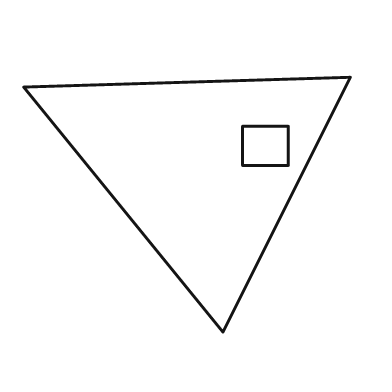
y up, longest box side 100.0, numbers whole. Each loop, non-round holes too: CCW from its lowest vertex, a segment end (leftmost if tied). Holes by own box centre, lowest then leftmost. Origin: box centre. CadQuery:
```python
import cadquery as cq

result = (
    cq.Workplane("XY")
    .moveTo(11.0, -39.0)
    .lineTo(50.0, 39.0)
    .lineTo(-50.0, 36.0)
    .close()
    .moveTo(17.0, 12.0)
    .lineTo(31.0, 12.0)
    .lineTo(31.0, 24.0)
    .lineTo(17.0, 24.0)
    .close()
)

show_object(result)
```